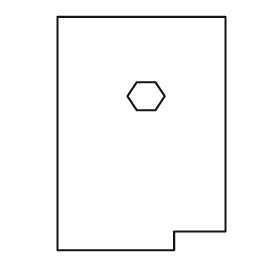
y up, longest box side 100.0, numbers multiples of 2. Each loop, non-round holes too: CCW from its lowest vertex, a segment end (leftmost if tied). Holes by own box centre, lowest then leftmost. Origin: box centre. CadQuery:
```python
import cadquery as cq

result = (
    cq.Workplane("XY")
    .moveTo(-36.0, -50.0)
    .lineTo(14.0, -50.0)
    .lineTo(14.0, -42.0)
    .lineTo(36.0, -42.0)
    .lineTo(36.0, 50.0)
    .lineTo(-36.0, 50.0)
    .close()
    .moveTo(-2.0, 10.0)
    .lineTo(6.0, 10.0)
    .lineTo(10.0, 16.0)
    .lineTo(6.0, 22.0)
    .lineTo(-2.0, 22.0)
    .lineTo(-6.0, 16.0)
    .close()
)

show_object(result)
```